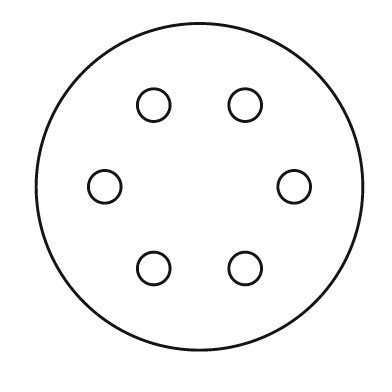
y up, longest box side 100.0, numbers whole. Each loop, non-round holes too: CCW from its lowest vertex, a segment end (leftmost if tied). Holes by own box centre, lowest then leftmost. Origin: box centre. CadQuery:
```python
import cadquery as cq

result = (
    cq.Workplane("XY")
    .moveTo(0.0, 0.0)
    .circle(50.0)
    .moveTo(-14.0, -25.0)
    .circle(5.0)
    .moveTo(14.0, -25.0)
    .circle(5.0)
    .moveTo(-29.0, 0.0)
    .circle(5.0)
    .moveTo(29.0, 0.0)
    .circle(5.0)
    .moveTo(-14.0, 25.0)
    .circle(5.0)
    .moveTo(14.0, 25.0)
    .circle(5.0)
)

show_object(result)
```